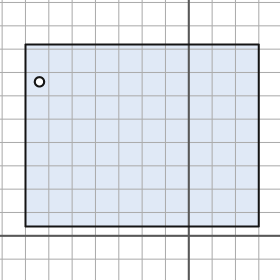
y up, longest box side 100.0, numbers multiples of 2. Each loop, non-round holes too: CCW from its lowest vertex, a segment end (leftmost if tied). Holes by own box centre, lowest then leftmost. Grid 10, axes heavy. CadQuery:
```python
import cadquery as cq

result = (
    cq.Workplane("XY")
    .moveTo(-70.0, 4.0)
    .lineTo(30.0, 4.0)
    .lineTo(30.0, 82.0)
    .lineTo(-70.0, 82.0)
    .close()
    .moveTo(-64.0, 66.0)
    .circle(2.0)
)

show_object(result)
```